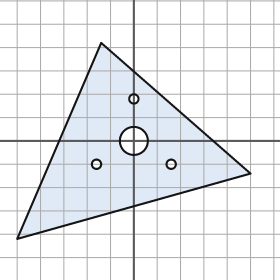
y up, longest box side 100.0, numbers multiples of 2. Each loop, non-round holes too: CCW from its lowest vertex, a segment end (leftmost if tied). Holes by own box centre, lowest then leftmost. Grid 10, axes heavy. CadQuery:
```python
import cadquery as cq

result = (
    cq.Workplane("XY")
    .moveTo(-50.0, -42.0)
    .lineTo(50.0, -14.0)
    .lineTo(-14.0, 42.0)
    .close()
    .moveTo(-16.0, -10.0)
    .circle(2.0)
    .moveTo(16.0, -10.0)
    .circle(2.0)
    .moveTo(0.0, 0.0)
    .circle(6.0)
    .moveTo(0.0, 18.0)
    .circle(2.0)
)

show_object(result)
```